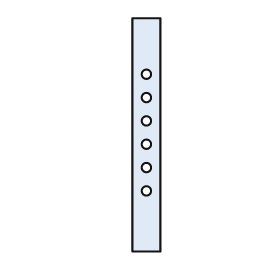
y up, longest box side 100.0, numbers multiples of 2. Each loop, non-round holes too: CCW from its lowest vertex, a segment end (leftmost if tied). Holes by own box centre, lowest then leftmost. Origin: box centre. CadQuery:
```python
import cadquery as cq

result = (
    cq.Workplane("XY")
    .moveTo(-6.0, -50.0)
    .lineTo(6.0, -50.0)
    .lineTo(6.0, 50.0)
    .lineTo(-6.0, 50.0)
    .close()
    .moveTo(0.0, -24.0)
    .circle(2.0)
    .moveTo(0.0, -14.0)
    .circle(2.0)
    .moveTo(0.0, -4.0)
    .circle(2.0)
    .moveTo(0.0, 6.0)
    .circle(2.0)
    .moveTo(0.0, 16.0)
    .circle(2.0)
    .moveTo(0.0, 26.0)
    .circle(2.0)
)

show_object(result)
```